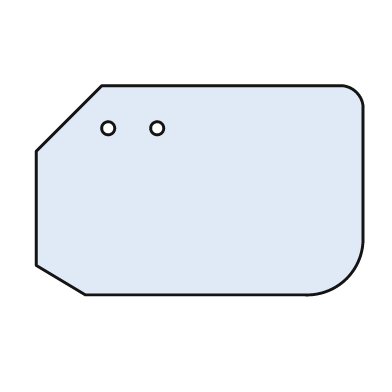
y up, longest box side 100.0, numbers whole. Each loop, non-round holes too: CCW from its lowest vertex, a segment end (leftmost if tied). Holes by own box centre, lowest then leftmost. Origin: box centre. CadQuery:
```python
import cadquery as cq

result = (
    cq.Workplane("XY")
    .moveTo(-35.0, -32.0)
    .lineTo(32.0, -32.0)
    .threePointArc((45.0, -27.0), (50.0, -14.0))
    .lineTo(50.0, 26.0)
    .threePointArc((48.0, 30.0), (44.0, 32.0))
    .lineTo(-30.0, 32.0)
    .lineTo(-50.0, 12.0)
    .lineTo(-50.0, -23.0)
    .close()
    .moveTo(-28.0, 19.0)
    .circle(2.0)
    .moveTo(-13.0, 19.0)
    .circle(2.0)
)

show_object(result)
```